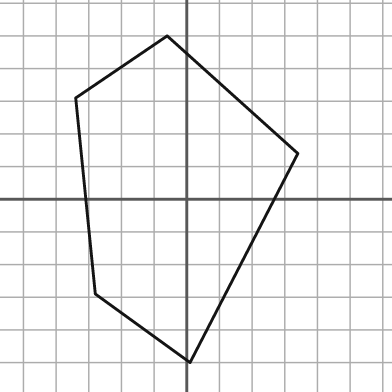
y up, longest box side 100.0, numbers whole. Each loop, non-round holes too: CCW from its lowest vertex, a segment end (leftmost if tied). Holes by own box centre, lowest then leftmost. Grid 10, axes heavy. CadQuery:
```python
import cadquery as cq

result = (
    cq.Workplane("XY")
    .moveTo(1.0, -50.0)
    .lineTo(34.0, 14.0)
    .lineTo(-6.0, 50.0)
    .lineTo(-34.0, 31.0)
    .lineTo(-28.0, -29.0)
    .close()
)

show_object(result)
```